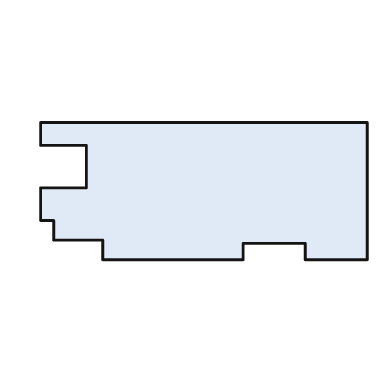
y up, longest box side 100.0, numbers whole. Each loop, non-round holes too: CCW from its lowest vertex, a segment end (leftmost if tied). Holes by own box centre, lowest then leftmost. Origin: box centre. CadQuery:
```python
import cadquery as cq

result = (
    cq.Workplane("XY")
    .moveTo(-31.0, -21.0)
    .lineTo(12.0, -21.0)
    .lineTo(12.0, -16.0)
    .lineTo(31.0, -16.0)
    .lineTo(31.0, -21.0)
    .lineTo(50.0, -21.0)
    .lineTo(50.0, 21.0)
    .lineTo(-50.0, 21.0)
    .lineTo(-50.0, 14.0)
    .lineTo(-36.0, 14.0)
    .lineTo(-36.0, 1.0)
    .lineTo(-50.0, 1.0)
    .lineTo(-50.0, -9.0)
    .lineTo(-46.0, -9.0)
    .lineTo(-46.0, -15.0)
    .lineTo(-31.0, -15.0)
    .close()
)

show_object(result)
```